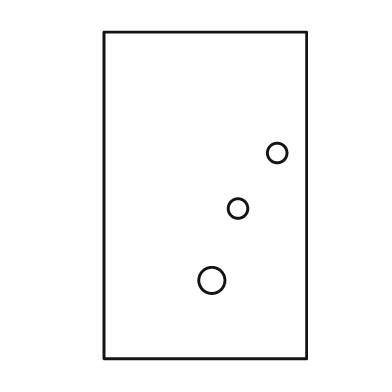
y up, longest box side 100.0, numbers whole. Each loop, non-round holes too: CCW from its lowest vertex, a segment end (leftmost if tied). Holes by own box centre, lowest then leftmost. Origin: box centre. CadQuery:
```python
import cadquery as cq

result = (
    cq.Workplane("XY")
    .moveTo(-31.0, -50.0)
    .lineTo(31.0, -50.0)
    .lineTo(31.0, 50.0)
    .lineTo(-31.0, 50.0)
    .close()
    .moveTo(2.0, -26.0)
    .circle(4.0)
    .moveTo(10.0, -4.0)
    .circle(3.0)
    .moveTo(22.0, 13.0)
    .circle(3.0)
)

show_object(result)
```